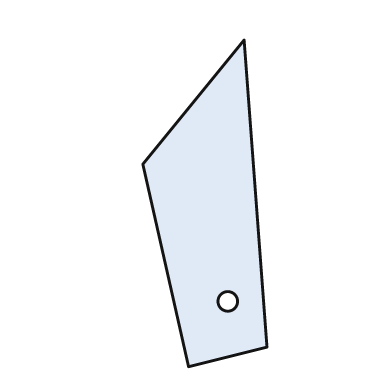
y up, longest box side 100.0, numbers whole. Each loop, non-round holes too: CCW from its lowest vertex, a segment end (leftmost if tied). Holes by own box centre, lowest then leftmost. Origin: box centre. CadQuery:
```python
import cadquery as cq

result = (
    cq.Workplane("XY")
    .moveTo(-5.0, -50.0)
    .lineTo(19.0, -44.0)
    .lineTo(12.0, 50.0)
    .lineTo(-19.0, 12.0)
    .close()
    .moveTo(7.0, -30.0)
    .circle(3.0)
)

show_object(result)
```